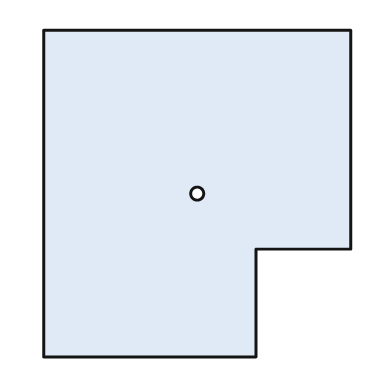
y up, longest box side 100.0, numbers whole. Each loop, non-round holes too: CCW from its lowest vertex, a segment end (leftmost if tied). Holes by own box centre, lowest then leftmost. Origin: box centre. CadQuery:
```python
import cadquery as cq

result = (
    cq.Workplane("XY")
    .moveTo(-47.0, -50.0)
    .lineTo(18.0, -50.0)
    .lineTo(18.0, -17.0)
    .lineTo(47.0, -17.0)
    .lineTo(47.0, 50.0)
    .lineTo(-47.0, 50.0)
    .close()
    .moveTo(0.0, 0.0)
    .circle(2.0)
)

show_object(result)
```